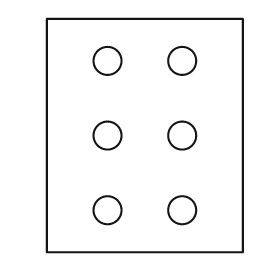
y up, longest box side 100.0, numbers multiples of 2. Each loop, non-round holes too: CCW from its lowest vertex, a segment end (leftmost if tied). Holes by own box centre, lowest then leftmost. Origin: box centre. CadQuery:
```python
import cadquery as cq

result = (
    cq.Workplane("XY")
    .moveTo(-42.0, -50.0)
    .lineTo(42.0, -50.0)
    .lineTo(42.0, 50.0)
    .lineTo(-42.0, 50.0)
    .close()
    .moveTo(-16.0, -32.0)
    .circle(6.0)
    .moveTo(16.0, -32.0)
    .circle(6.0)
    .moveTo(-16.0, 0.0)
    .circle(6.0)
    .moveTo(16.0, 0.0)
    .circle(6.0)
    .moveTo(-16.0, 32.0)
    .circle(6.0)
    .moveTo(16.0, 32.0)
    .circle(6.0)
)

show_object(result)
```